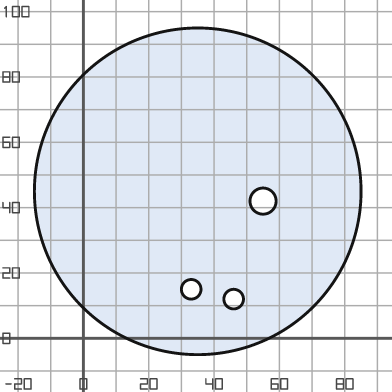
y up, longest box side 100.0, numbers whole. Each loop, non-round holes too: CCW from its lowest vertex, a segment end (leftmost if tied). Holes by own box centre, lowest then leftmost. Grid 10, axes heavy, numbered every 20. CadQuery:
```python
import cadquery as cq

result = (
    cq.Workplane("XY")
    .moveTo(35.0, 45.0)
    .circle(50.0)
    .moveTo(46.0, 12.0)
    .circle(3.0)
    .moveTo(33.0, 15.0)
    .circle(3.0)
    .moveTo(55.0, 42.0)
    .circle(4.0)
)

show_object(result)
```